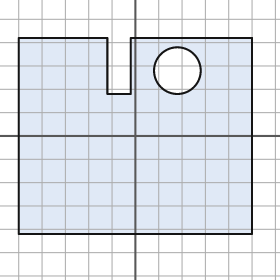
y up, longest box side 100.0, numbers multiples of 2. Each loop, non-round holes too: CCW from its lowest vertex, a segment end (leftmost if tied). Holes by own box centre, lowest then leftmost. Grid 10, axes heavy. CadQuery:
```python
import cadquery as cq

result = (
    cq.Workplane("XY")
    .moveTo(-50.0, -42.0)
    .lineTo(50.0, -42.0)
    .lineTo(50.0, 42.0)
    .lineTo(-2.0, 42.0)
    .lineTo(-2.0, 18.0)
    .lineTo(-12.0, 18.0)
    .lineTo(-12.0, 42.0)
    .lineTo(-50.0, 42.0)
    .close()
    .moveTo(18.0, 28.0)
    .circle(10.0)
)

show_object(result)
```